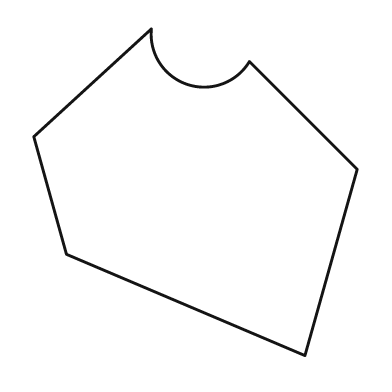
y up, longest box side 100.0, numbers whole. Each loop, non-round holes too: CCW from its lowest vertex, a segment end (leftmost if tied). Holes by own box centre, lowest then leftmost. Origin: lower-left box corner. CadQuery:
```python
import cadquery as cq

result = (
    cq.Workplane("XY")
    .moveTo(83.0, 0.0)
    .lineTo(99.0, 57.0)
    .lineTo(66.0, 90.0)
    .threePointArc((47.0, 83.0), (36.0, 100.0))
    .lineTo(0.0, 67.0)
    .lineTo(10.0, 31.0)
    .close()
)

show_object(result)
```